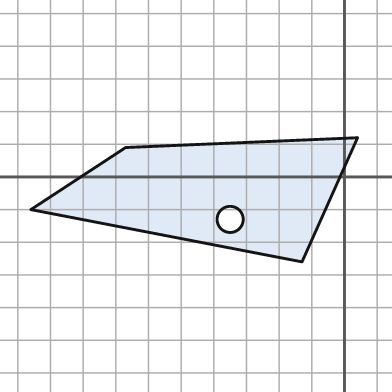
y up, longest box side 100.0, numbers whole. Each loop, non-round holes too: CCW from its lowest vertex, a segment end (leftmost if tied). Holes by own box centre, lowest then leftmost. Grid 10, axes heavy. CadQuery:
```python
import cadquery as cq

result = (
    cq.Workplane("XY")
    .moveTo(-13.0, -26.0)
    .lineTo(4.0, 12.0)
    .lineTo(-67.0, 9.0)
    .lineTo(-96.0, -10.0)
    .close()
    .moveTo(-35.0, -13.0)
    .circle(4.0)
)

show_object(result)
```